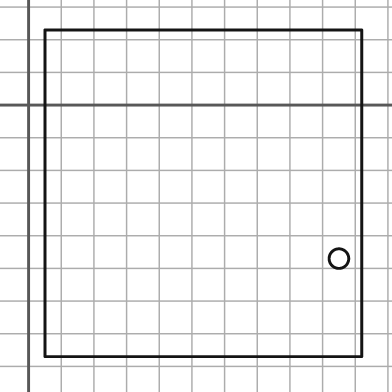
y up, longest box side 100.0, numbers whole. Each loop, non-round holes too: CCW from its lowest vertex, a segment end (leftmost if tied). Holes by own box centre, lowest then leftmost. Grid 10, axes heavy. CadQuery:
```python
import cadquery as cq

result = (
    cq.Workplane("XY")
    .moveTo(5.0, -77.0)
    .lineTo(102.0, -77.0)
    .lineTo(102.0, 23.0)
    .lineTo(5.0, 23.0)
    .close()
    .moveTo(95.0, -47.0)
    .circle(3.0)
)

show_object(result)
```